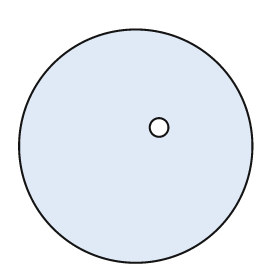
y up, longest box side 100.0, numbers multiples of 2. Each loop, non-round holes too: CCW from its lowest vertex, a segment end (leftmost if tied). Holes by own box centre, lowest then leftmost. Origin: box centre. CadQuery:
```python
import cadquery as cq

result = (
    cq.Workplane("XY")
    .moveTo(0.0, 0.0)
    .circle(50.0)
    .moveTo(10.0, 8.0)
    .circle(4.0)
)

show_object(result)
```